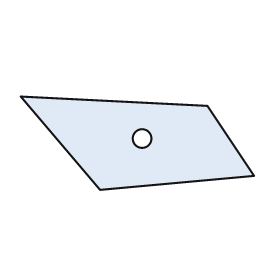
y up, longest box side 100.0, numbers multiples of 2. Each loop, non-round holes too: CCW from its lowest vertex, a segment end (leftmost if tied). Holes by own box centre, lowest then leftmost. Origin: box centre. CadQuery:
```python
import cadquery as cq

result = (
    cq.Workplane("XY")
    .moveTo(-16.0, -20.0)
    .lineTo(50.0, -14.0)
    .lineTo(30.0, 16.0)
    .lineTo(-50.0, 20.0)
    .close()
    .moveTo(2.0, 2.0)
    .circle(4.0)
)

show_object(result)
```